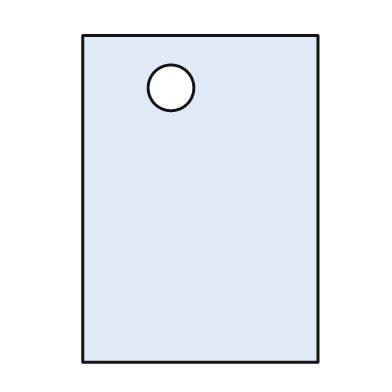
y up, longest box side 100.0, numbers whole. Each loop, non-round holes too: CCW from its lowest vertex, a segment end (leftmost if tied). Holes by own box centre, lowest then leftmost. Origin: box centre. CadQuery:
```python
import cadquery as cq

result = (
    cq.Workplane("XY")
    .moveTo(-36.0, -50.0)
    .lineTo(36.0, -50.0)
    .lineTo(36.0, 50.0)
    .lineTo(-36.0, 50.0)
    .close()
    .moveTo(-9.0, 34.0)
    .circle(7.0)
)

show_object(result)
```